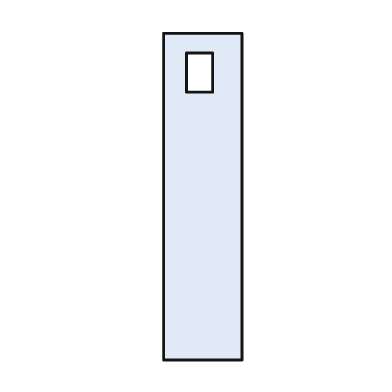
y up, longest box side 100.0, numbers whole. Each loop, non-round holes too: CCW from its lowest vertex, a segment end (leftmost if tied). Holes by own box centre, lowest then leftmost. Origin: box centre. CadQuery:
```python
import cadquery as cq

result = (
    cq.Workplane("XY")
    .moveTo(-12.0, -50.0)
    .lineTo(12.0, -50.0)
    .lineTo(12.0, 50.0)
    .lineTo(-12.0, 50.0)
    .close()
    .moveTo(-5.0, 32.0)
    .lineTo(3.0, 32.0)
    .lineTo(3.0, 44.0)
    .lineTo(-5.0, 44.0)
    .close()
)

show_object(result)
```